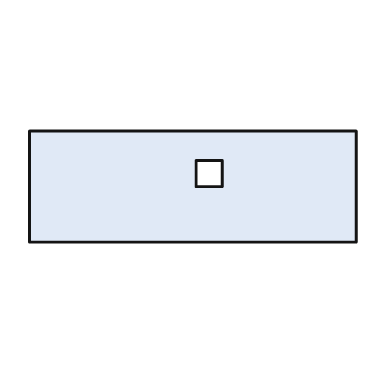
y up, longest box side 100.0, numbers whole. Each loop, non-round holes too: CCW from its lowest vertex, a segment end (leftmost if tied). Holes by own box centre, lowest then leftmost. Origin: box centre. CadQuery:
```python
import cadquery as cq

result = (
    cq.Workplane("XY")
    .moveTo(-50.0, -17.0)
    .lineTo(50.0, -17.0)
    .lineTo(50.0, 17.0)
    .lineTo(-50.0, 17.0)
    .close()
    .moveTo(1.0, 0.0)
    .lineTo(9.0, 0.0)
    .lineTo(9.0, 8.0)
    .lineTo(1.0, 8.0)
    .close()
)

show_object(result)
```